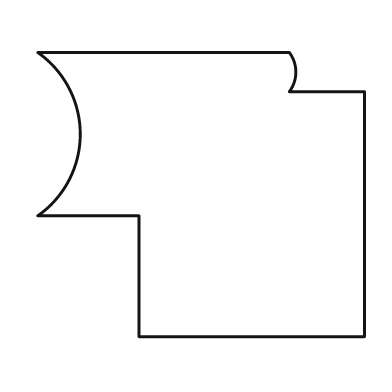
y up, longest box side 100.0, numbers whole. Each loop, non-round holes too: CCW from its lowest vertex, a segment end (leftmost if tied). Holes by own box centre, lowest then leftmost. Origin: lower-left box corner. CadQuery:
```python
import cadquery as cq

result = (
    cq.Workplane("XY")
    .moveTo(31.0, 0.0)
    .lineTo(100.0, 0.0)
    .lineTo(100.0, 75.0)
    .lineTo(77.0, 75.0)
    .threePointArc((79.0, 81.0), (77.0, 87.0))
    .lineTo(0.0, 87.0)
    .threePointArc((13.0, 62.0), (0.0, 37.0))
    .lineTo(31.0, 37.0)
    .close()
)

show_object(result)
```